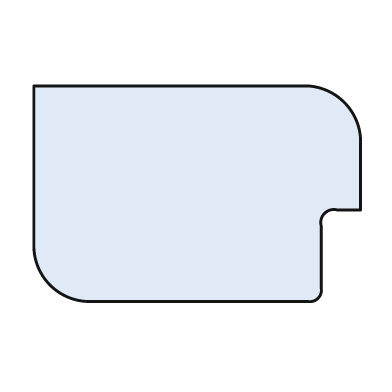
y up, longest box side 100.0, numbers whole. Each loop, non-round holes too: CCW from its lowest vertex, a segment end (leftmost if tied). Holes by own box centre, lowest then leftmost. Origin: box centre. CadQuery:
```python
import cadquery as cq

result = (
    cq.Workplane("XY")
    .moveTo(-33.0, -33.0)
    .lineTo(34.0, -33.0)
    .threePointArc((37.0, -32.0), (38.0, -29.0))
    .lineTo(38.0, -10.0)
    .threePointArc((39.0, -6.0), (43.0, -5.0))
    .lineTo(50.0, -5.0)
    .lineTo(50.0, 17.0)
    .threePointArc((45.0, 28.0), (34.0, 33.0))
    .lineTo(-50.0, 33.0)
    .lineTo(-50.0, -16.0)
    .threePointArc((-45.0, -28.0), (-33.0, -33.0))
    .close()
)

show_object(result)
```